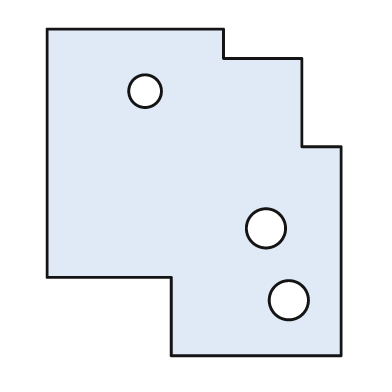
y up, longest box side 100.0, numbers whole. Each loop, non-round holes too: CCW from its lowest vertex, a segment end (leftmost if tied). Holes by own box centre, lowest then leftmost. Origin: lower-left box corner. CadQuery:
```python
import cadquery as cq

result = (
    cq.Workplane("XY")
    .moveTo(38.0, 0.0)
    .lineTo(90.0, 0.0)
    .lineTo(90.0, 64.0)
    .lineTo(78.0, 64.0)
    .lineTo(78.0, 91.0)
    .lineTo(54.0, 91.0)
    .lineTo(54.0, 100.0)
    .lineTo(0.0, 100.0)
    .lineTo(0.0, 24.0)
    .lineTo(38.0, 24.0)
    .close()
    .moveTo(74.0, 17.0)
    .circle(6.0)
    .moveTo(67.0, 39.0)
    .circle(6.0)
    .moveTo(30.0, 81.0)
    .circle(5.0)
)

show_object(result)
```